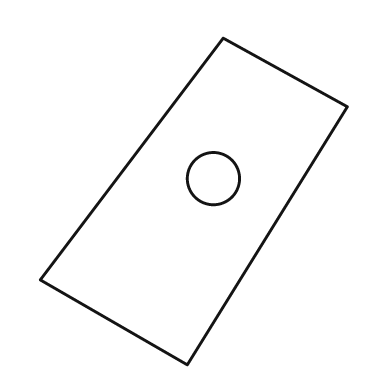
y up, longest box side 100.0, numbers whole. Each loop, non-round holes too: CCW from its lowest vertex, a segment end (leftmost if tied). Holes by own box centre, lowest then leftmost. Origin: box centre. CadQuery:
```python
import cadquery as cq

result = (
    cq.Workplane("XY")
    .moveTo(-2.0, -50.0)
    .lineTo(47.0, 29.0)
    .lineTo(9.0, 50.0)
    .lineTo(-47.0, -24.0)
    .close()
    .moveTo(6.0, 7.0)
    .circle(8.0)
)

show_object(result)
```